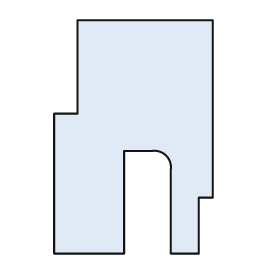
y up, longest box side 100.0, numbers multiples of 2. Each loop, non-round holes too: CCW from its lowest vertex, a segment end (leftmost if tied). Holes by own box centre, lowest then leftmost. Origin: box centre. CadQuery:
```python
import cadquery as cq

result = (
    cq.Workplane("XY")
    .moveTo(-34.0, -50.0)
    .lineTo(-4.0, -50.0)
    .lineTo(-4.0, -6.0)
    .lineTo(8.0, -6.0)
    .threePointArc((14.0, -8.0), (16.0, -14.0))
    .lineTo(16.0, -50.0)
    .lineTo(28.0, -50.0)
    .lineTo(28.0, -26.0)
    .lineTo(34.0, -26.0)
    .lineTo(34.0, 50.0)
    .lineTo(-24.0, 50.0)
    .lineTo(-24.0, 10.0)
    .lineTo(-34.0, 10.0)
    .close()
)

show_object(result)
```